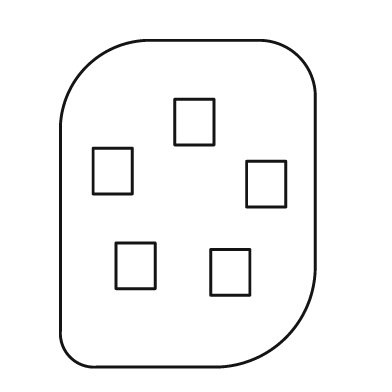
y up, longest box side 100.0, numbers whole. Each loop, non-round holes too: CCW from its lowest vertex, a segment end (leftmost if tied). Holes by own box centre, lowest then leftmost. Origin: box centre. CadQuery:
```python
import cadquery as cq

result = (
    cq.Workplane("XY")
    .moveTo(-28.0, -50.0)
    .lineTo(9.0, -50.0)
    .threePointArc((30.0, -41.0), (39.0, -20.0))
    .lineTo(39.0, 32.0)
    .threePointArc((34.0, 45.0), (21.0, 50.0))
    .lineTo(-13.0, 50.0)
    .threePointArc((-31.0, 42.0), (-39.0, 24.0))
    .lineTo(-39.0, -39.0)
    .threePointArc((-36.0, -47.0), (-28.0, -50.0))
    .close()
    .moveTo(7.0, -28.0)
    .lineTo(19.0, -28.0)
    .lineTo(19.0, -14.0)
    .lineTo(7.0, -14.0)
    .close()
    .moveTo(-22.0, -26.0)
    .lineTo(-10.0, -26.0)
    .lineTo(-10.0, -12.0)
    .lineTo(-22.0, -12.0)
    .close()
    .moveTo(18.0, -1.0)
    .lineTo(30.0, -1.0)
    .lineTo(30.0, 13.0)
    .lineTo(18.0, 13.0)
    .close()
    .moveTo(-29.0, 3.0)
    .lineTo(-17.0, 3.0)
    .lineTo(-17.0, 17.0)
    .lineTo(-29.0, 17.0)
    .close()
    .moveTo(-4.0, 18.0)
    .lineTo(8.0, 18.0)
    .lineTo(8.0, 32.0)
    .lineTo(-4.0, 32.0)
    .close()
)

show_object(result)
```